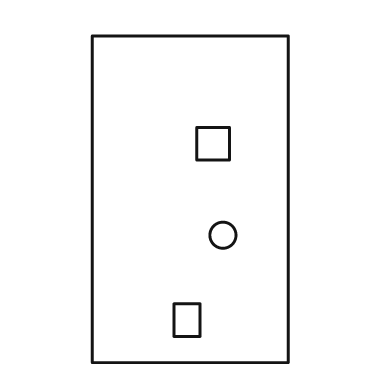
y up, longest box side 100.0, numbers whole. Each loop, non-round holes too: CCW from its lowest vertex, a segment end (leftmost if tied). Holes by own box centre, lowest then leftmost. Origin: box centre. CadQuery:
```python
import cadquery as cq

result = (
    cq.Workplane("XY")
    .moveTo(-30.0, -50.0)
    .lineTo(30.0, -50.0)
    .lineTo(30.0, 50.0)
    .lineTo(-30.0, 50.0)
    .close()
    .moveTo(-5.0, -42.0)
    .lineTo(3.0, -42.0)
    .lineTo(3.0, -32.0)
    .lineTo(-5.0, -32.0)
    .close()
    .moveTo(10.0, -11.0)
    .circle(4.0)
    .moveTo(2.0, 12.0)
    .lineTo(12.0, 12.0)
    .lineTo(12.0, 22.0)
    .lineTo(2.0, 22.0)
    .close()
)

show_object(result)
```